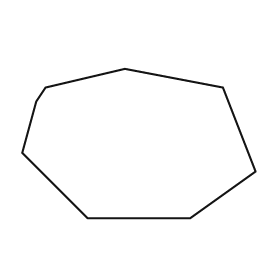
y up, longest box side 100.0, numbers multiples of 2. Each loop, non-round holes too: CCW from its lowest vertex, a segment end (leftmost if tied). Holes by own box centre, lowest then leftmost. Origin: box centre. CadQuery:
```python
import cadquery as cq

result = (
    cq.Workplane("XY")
    .moveTo(-22.0, -32.0)
    .lineTo(22.0, -32.0)
    .lineTo(50.0, -12.0)
    .lineTo(36.0, 24.0)
    .lineTo(-6.0, 32.0)
    .lineTo(-40.0, 24.0)
    .lineTo(-44.0, 18.0)
    .lineTo(-50.0, -4.0)
    .close()
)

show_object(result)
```